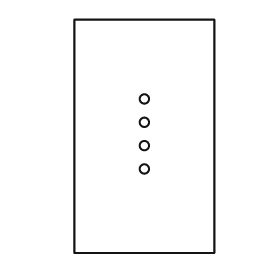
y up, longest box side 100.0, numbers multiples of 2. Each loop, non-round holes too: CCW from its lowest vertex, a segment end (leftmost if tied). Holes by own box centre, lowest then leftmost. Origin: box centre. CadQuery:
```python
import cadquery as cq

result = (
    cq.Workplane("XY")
    .moveTo(-30.0, -50.0)
    .lineTo(30.0, -50.0)
    .lineTo(30.0, 50.0)
    .lineTo(-30.0, 50.0)
    .close()
    .moveTo(0.0, -14.0)
    .circle(2.0)
    .moveTo(0.0, -4.0)
    .circle(2.0)
    .moveTo(0.0, 6.0)
    .circle(2.0)
    .moveTo(0.0, 16.0)
    .circle(2.0)
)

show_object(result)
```